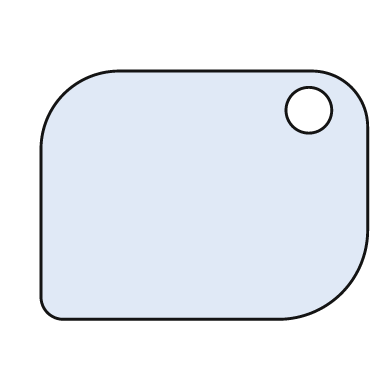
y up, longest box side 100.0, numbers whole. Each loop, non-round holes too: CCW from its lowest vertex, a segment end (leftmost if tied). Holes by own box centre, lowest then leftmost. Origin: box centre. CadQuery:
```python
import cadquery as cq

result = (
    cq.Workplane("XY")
    .moveTo(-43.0, -38.0)
    .lineTo(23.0, -38.0)
    .threePointArc((42.0, -30.0), (50.0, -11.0))
    .lineTo(50.0, 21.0)
    .threePointArc((45.0, 33.0), (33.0, 38.0))
    .lineTo(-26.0, 38.0)
    .threePointArc((-43.0, 31.0), (-50.0, 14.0))
    .lineTo(-50.0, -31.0)
    .threePointArc((-48.0, -36.0), (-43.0, -38.0))
    .close()
    .moveTo(32.0, 26.0)
    .circle(7.0)
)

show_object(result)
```